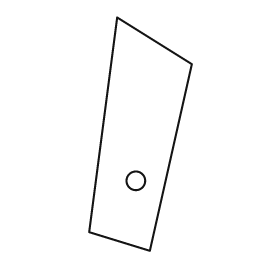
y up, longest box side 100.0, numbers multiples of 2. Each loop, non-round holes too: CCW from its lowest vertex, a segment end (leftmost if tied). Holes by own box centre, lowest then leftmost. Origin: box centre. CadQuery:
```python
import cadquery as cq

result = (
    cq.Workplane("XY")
    .moveTo(4.0, -50.0)
    .lineTo(22.0, 30.0)
    .lineTo(-10.0, 50.0)
    .lineTo(-22.0, -42.0)
    .close()
    .moveTo(-2.0, -20.0)
    .circle(4.0)
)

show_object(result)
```